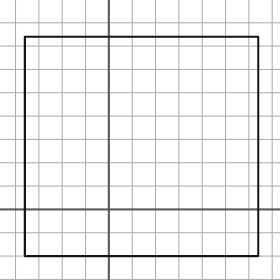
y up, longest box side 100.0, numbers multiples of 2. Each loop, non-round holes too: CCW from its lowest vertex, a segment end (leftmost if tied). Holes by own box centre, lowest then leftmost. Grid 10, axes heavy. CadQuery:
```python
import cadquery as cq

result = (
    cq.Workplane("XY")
    .moveTo(-36.0, -20.0)
    .lineTo(64.0, -20.0)
    .lineTo(64.0, 74.0)
    .lineTo(-36.0, 74.0)
    .close()
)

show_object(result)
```